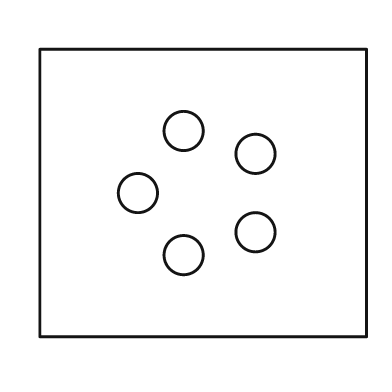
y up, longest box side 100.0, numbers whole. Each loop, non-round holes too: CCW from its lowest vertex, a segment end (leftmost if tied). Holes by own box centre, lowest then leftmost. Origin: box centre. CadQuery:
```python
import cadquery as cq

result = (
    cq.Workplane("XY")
    .moveTo(-50.0, -44.0)
    .lineTo(50.0, -44.0)
    .lineTo(50.0, 44.0)
    .lineTo(-50.0, 44.0)
    .close()
    .moveTo(-6.0, -19.0)
    .circle(6.0)
    .moveTo(16.0, -12.0)
    .circle(6.0)
    .moveTo(-20.0, 0.0)
    .circle(6.0)
    .moveTo(16.0, 12.0)
    .circle(6.0)
    .moveTo(-6.0, 19.0)
    .circle(6.0)
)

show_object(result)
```